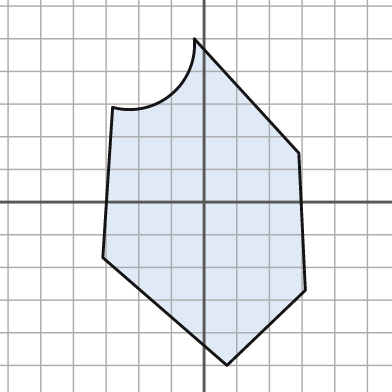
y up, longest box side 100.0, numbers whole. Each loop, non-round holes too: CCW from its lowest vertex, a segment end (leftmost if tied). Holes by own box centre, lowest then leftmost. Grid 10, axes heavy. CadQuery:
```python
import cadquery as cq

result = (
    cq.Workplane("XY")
    .moveTo(7.0, -50.0)
    .lineTo(31.0, -27.0)
    .lineTo(29.0, 15.0)
    .lineTo(-3.0, 50.0)
    .threePointArc((-10.0, 33.0), (-28.0, 29.0))
    .lineTo(-31.0, -17.0)
    .close()
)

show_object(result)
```